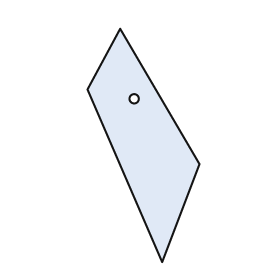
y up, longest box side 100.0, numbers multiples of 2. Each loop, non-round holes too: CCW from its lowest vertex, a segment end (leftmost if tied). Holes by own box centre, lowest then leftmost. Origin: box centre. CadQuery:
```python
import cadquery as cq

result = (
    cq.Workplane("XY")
    .moveTo(8.0, -50.0)
    .lineTo(24.0, -8.0)
    .lineTo(-10.0, 50.0)
    .lineTo(-24.0, 24.0)
    .close()
    .moveTo(-4.0, 20.0)
    .circle(2.0)
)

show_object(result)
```